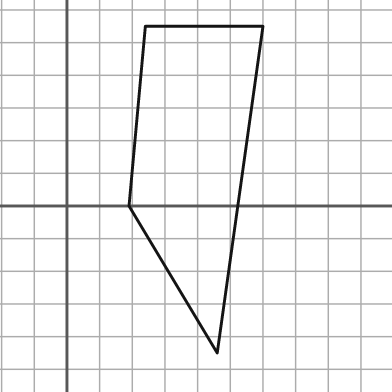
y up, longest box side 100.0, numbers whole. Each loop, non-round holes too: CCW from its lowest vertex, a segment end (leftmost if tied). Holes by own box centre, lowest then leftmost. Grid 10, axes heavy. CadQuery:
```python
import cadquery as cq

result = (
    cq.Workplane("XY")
    .moveTo(46.0, -45.0)
    .lineTo(60.0, 55.0)
    .lineTo(24.0, 55.0)
    .lineTo(19.0, 0.0)
    .close()
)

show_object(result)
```